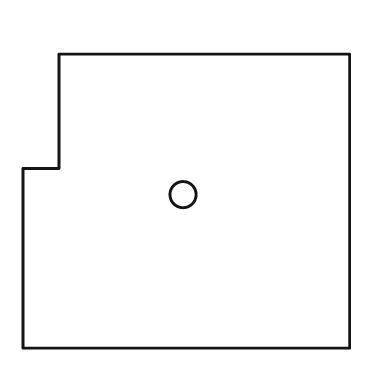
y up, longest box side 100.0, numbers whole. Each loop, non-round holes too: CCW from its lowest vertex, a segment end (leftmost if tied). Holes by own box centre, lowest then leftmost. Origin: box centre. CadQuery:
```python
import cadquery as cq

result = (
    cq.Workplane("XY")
    .moveTo(-50.0, -45.0)
    .lineTo(50.0, -45.0)
    .lineTo(50.0, 45.0)
    .lineTo(-39.0, 45.0)
    .lineTo(-39.0, 10.0)
    .lineTo(-50.0, 10.0)
    .close()
    .moveTo(-1.0, 2.0)
    .circle(4.0)
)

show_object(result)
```